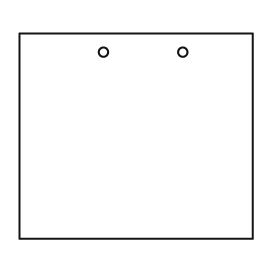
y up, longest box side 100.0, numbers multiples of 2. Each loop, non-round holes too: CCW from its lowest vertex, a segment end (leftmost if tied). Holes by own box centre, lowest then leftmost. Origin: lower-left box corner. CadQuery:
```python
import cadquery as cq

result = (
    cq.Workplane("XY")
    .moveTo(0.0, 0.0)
    .lineTo(100.0, 0.0)
    .lineTo(100.0, 88.0)
    .lineTo(0.0, 88.0)
    .close()
    .moveTo(36.0, 80.0)
    .circle(2.0)
    .moveTo(70.0, 80.0)
    .circle(2.0)
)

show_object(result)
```